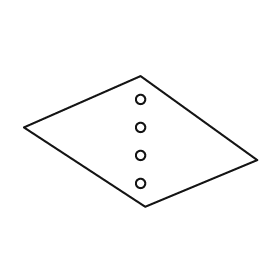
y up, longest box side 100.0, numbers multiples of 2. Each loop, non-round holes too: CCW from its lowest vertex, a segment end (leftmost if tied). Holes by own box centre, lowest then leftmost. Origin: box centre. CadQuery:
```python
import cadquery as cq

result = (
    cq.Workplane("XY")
    .moveTo(2.0, -28.0)
    .lineTo(50.0, -8.0)
    .lineTo(0.0, 28.0)
    .lineTo(-50.0, 6.0)
    .close()
    .moveTo(0.0, -18.0)
    .circle(2.0)
    .moveTo(0.0, -6.0)
    .circle(2.0)
    .moveTo(0.0, 6.0)
    .circle(2.0)
    .moveTo(0.0, 18.0)
    .circle(2.0)
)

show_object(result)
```